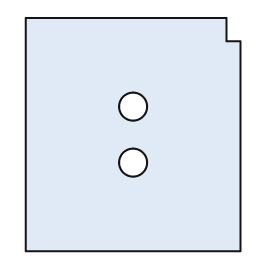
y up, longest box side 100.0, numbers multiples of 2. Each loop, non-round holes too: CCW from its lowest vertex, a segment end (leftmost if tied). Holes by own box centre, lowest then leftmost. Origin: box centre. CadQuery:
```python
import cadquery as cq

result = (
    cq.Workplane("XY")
    .moveTo(-46.0, -50.0)
    .lineTo(46.0, -50.0)
    .lineTo(46.0, 40.0)
    .lineTo(40.0, 40.0)
    .lineTo(40.0, 50.0)
    .lineTo(-46.0, 50.0)
    .close()
    .moveTo(0.0, -12.0)
    .circle(6.0)
    .moveTo(0.0, 12.0)
    .circle(6.0)
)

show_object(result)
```